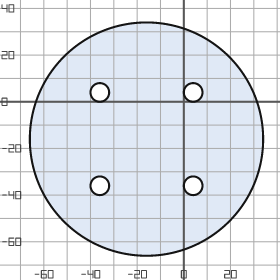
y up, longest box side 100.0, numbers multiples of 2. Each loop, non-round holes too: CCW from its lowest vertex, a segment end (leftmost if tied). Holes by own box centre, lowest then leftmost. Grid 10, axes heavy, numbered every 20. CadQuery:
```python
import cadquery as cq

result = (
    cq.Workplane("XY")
    .moveTo(-16.0, -16.0)
    .circle(50.0)
    .moveTo(-36.0, -36.0)
    .circle(4.0)
    .moveTo(4.0, -36.0)
    .circle(4.0)
    .moveTo(-36.0, 4.0)
    .circle(4.0)
    .moveTo(4.0, 4.0)
    .circle(4.0)
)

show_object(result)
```